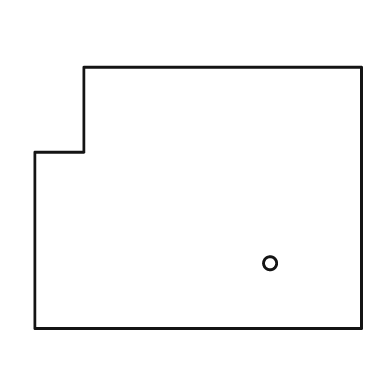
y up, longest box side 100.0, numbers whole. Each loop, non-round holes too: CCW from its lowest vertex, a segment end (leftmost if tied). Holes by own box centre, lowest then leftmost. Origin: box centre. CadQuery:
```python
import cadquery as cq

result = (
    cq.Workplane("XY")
    .moveTo(-50.0, -40.0)
    .lineTo(50.0, -40.0)
    .lineTo(50.0, 40.0)
    .lineTo(-35.0, 40.0)
    .lineTo(-35.0, 14.0)
    .lineTo(-50.0, 14.0)
    .close()
    .moveTo(22.0, -20.0)
    .circle(2.0)
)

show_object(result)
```